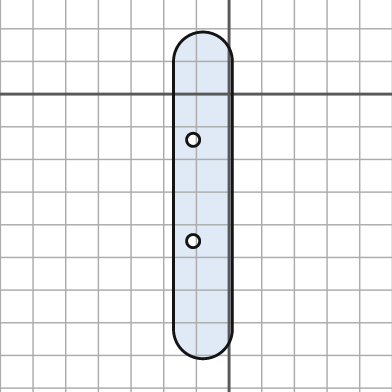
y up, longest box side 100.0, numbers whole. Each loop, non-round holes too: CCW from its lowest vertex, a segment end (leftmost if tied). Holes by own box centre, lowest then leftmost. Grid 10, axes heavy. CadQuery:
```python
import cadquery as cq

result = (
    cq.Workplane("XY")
    .moveTo(-17.0, -72.0)
    .threePointArc((-8.0, -81.0), (1.0, -72.0))
    .lineTo(1.0, 10.0)
    .threePointArc((-8.0, 19.0), (-17.0, 10.0))
    .close()
    .moveTo(-11.0, -45.0)
    .circle(2.0)
    .moveTo(-11.0, -14.0)
    .circle(2.0)
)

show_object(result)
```